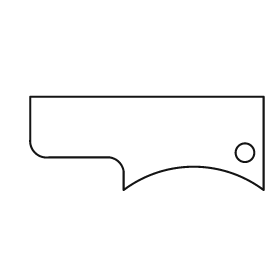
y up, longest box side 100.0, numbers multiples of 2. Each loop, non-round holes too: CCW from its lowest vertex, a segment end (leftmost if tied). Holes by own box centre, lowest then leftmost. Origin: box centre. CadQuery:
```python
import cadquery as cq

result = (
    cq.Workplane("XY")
    .moveTo(-10.0, -20.0)
    .threePointArc((20.0, -10.0), (50.0, -20.0))
    .lineTo(50.0, 20.0)
    .lineTo(-50.0, 20.0)
    .lineTo(-50.0, 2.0)
    .threePointArc((-48.0, -4.0), (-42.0, -6.0))
    .lineTo(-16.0, -6.0)
    .threePointArc((-12.0, -8.0), (-10.0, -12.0))
    .close()
    .moveTo(42.0, -4.0)
    .circle(4.0)
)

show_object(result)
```